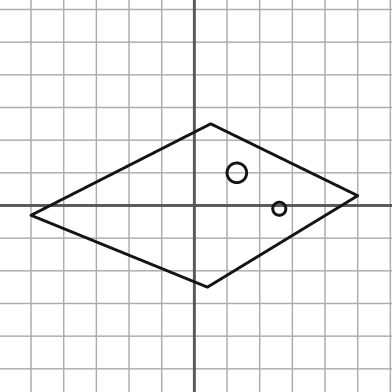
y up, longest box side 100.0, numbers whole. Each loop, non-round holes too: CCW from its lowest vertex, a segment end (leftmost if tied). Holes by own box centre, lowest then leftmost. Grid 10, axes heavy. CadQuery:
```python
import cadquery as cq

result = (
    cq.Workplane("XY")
    .moveTo(4.0, -25.0)
    .lineTo(50.0, 3.0)
    .lineTo(5.0, 25.0)
    .lineTo(-50.0, -3.0)
    .close()
    .moveTo(26.0, -1.0)
    .circle(2.0)
    .moveTo(13.0, 10.0)
    .circle(3.0)
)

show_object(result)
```